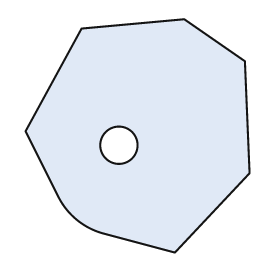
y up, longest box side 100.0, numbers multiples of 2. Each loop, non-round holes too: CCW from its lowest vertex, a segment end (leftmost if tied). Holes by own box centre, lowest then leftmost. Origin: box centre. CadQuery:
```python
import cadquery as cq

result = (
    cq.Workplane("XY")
    .moveTo(16.0, -50.0)
    .lineTo(48.0, -16.0)
    .lineTo(46.0, 32.0)
    .lineTo(20.0, 50.0)
    .lineTo(-24.0, 46.0)
    .lineTo(-48.0, 2.0)
    .lineTo(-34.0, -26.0)
    .threePointArc((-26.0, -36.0), (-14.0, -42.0))
    .close()
    .moveTo(-8.0, -4.0)
    .circle(8.0)
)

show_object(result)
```